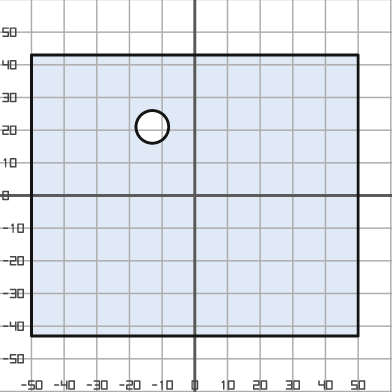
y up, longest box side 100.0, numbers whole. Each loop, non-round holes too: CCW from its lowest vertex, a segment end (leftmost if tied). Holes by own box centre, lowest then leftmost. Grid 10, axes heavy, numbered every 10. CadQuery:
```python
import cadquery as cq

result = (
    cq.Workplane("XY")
    .moveTo(-50.0, -43.0)
    .lineTo(50.0, -43.0)
    .lineTo(50.0, 43.0)
    .lineTo(-50.0, 43.0)
    .close()
    .moveTo(-13.0, 21.0)
    .circle(5.0)
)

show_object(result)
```